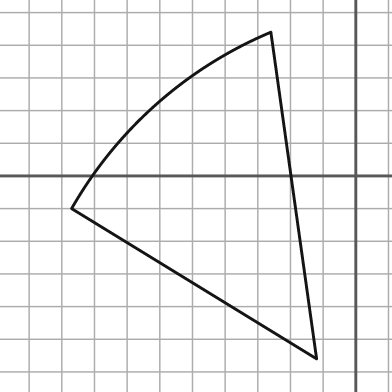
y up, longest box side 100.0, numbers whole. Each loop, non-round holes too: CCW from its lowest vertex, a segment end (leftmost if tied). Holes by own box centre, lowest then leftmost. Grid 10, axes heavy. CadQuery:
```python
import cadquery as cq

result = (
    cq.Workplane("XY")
    .moveTo(-12.0, -56.0)
    .lineTo(-26.0, 44.0)
    .threePointArc((-61.0, 22.0), (-87.0, -10.0))
    .close()
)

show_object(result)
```